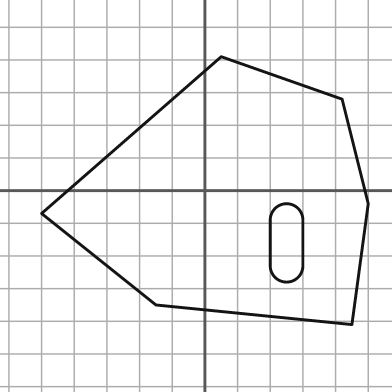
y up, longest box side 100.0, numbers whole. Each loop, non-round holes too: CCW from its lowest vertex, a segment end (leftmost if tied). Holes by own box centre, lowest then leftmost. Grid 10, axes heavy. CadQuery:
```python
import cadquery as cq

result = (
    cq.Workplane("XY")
    .moveTo(45.0, -41.0)
    .lineTo(50.0, -4.0)
    .lineTo(42.0, 28.0)
    .lineTo(5.0, 41.0)
    .lineTo(-50.0, -7.0)
    .lineTo(-15.0, -35.0)
    .close()
    .moveTo(20.0, -23.0)
    .threePointArc((25.0, -28.0), (30.0, -23.0))
    .lineTo(30.0, -9.0)
    .threePointArc((25.0, -4.0), (20.0, -9.0))
    .close()
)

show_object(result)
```